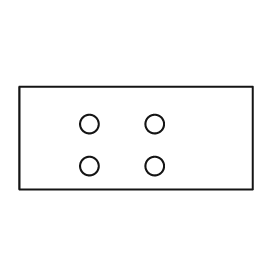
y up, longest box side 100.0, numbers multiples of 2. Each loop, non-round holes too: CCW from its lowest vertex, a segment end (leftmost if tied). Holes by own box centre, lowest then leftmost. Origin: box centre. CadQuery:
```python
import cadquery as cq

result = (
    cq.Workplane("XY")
    .moveTo(-50.0, -22.0)
    .lineTo(50.0, -22.0)
    .lineTo(50.0, 22.0)
    .lineTo(-50.0, 22.0)
    .close()
    .moveTo(-20.0, -12.0)
    .circle(4.0)
    .moveTo(8.0, -12.0)
    .circle(4.0)
    .moveTo(-20.0, 6.0)
    .circle(4.0)
    .moveTo(8.0, 6.0)
    .circle(4.0)
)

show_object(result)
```